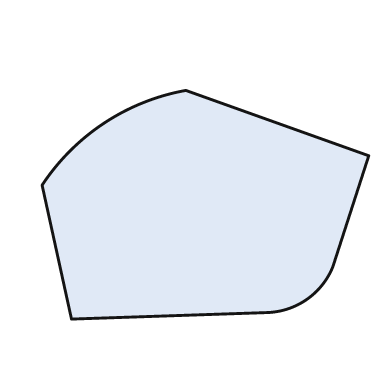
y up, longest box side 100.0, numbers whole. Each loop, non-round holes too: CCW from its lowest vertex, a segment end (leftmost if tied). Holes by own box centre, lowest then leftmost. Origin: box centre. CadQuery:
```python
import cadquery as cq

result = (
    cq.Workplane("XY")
    .moveTo(-41.0, -35.0)
    .lineTo(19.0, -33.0)
    .threePointArc((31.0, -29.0), (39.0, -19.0))
    .lineTo(50.0, 15.0)
    .lineTo(-6.0, 35.0)
    .threePointArc((-31.0, 25.0), (-50.0, 6.0))
    .close()
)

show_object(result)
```